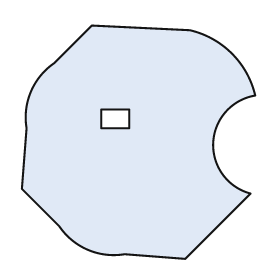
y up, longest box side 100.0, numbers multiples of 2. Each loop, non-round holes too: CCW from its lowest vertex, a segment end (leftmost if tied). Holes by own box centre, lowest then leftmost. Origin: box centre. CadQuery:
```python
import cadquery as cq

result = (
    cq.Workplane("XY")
    .moveTo(20.0, -50.0)
    .lineTo(48.0, -22.0)
    .threePointArc((32.0, 0.0), (50.0, 20.0))
    .threePointArc((40.0, 38.0), (22.0, 48.0))
    .lineTo(-20.0, 50.0)
    .lineTo(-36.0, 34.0)
    .threePointArc((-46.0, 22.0), (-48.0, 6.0))
    .lineTo(-50.0, -20.0)
    .lineTo(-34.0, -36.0)
    .threePointArc((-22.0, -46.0), (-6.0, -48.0))
    .close()
    .moveTo(-16.0, 6.0)
    .lineTo(-4.0, 6.0)
    .lineTo(-4.0, 14.0)
    .lineTo(-16.0, 14.0)
    .close()
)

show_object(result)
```